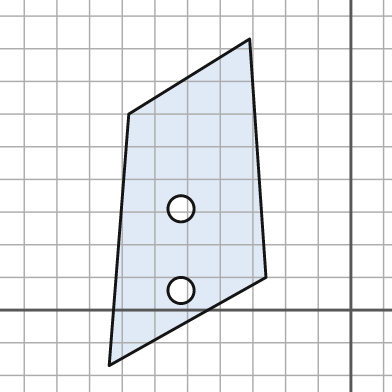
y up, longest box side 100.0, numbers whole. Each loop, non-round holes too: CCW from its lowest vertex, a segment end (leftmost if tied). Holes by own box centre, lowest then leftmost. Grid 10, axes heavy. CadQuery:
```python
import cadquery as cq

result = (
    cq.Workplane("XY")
    .moveTo(-74.0, -17.0)
    .lineTo(-26.0, 10.0)
    .lineTo(-31.0, 83.0)
    .lineTo(-68.0, 60.0)
    .close()
    .moveTo(-52.0, 6.0)
    .circle(4.0)
    .moveTo(-52.0, 31.0)
    .circle(4.0)
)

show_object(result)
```